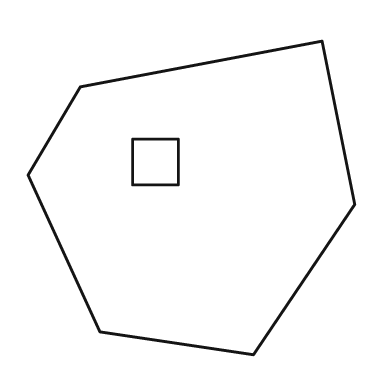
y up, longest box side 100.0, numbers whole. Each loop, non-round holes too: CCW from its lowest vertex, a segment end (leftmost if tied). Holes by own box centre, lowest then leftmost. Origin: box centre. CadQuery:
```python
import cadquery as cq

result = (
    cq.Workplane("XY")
    .moveTo(19.0, -48.0)
    .lineTo(50.0, -2.0)
    .lineTo(40.0, 48.0)
    .lineTo(-34.0, 34.0)
    .lineTo(-50.0, 7.0)
    .lineTo(-28.0, -41.0)
    .close()
    .moveTo(-18.0, 4.0)
    .lineTo(-4.0, 4.0)
    .lineTo(-4.0, 18.0)
    .lineTo(-18.0, 18.0)
    .close()
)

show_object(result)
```